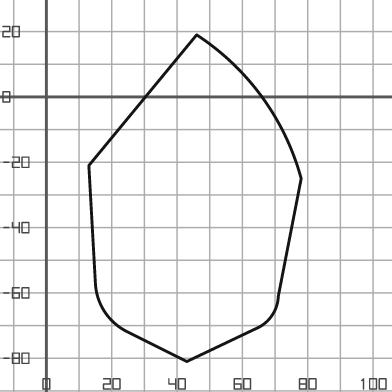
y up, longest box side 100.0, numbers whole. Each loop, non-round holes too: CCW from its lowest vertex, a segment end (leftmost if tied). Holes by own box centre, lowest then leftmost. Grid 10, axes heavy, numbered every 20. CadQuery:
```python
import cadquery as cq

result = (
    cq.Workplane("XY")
    .moveTo(43.0, -81.0)
    .lineTo(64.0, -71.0)
    .threePointArc((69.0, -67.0), (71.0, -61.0))
    .lineTo(78.0, -25.0)
    .threePointArc((66.0, 0.0), (46.0, 19.0))
    .lineTo(13.0, -21.0)
    .lineTo(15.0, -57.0)
    .threePointArc((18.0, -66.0), (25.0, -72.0))
    .close()
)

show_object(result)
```